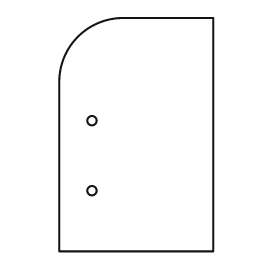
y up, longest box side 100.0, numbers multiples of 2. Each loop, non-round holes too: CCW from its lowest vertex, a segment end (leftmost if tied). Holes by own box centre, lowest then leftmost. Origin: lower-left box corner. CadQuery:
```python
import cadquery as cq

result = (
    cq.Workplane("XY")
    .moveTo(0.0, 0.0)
    .lineTo(66.0, 0.0)
    .lineTo(66.0, 100.0)
    .lineTo(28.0, 100.0)
    .threePointArc((8.0, 92.0), (0.0, 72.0))
    .close()
    .moveTo(14.0, 26.0)
    .circle(2.0)
    .moveTo(14.0, 56.0)
    .circle(2.0)
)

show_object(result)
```